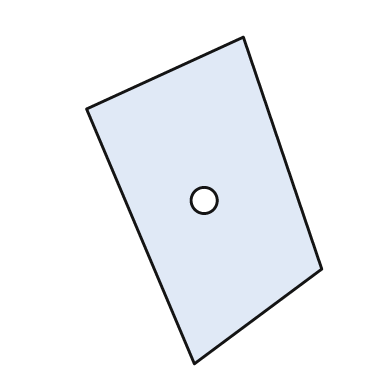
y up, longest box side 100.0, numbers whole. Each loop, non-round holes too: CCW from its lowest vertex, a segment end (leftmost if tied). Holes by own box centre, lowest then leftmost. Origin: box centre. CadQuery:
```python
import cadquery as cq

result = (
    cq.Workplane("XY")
    .moveTo(-3.0, -50.0)
    .lineTo(36.0, -21.0)
    .lineTo(12.0, 50.0)
    .lineTo(-36.0, 28.0)
    .close()
    .moveTo(0.0, 0.0)
    .circle(4.0)
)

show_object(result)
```